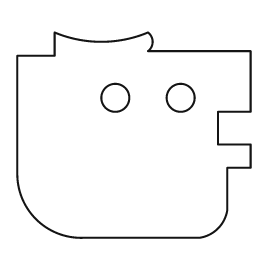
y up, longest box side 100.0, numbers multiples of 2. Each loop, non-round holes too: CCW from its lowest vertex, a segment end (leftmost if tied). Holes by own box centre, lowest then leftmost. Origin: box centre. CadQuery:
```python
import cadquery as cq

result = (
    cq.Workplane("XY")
    .moveTo(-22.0, -44.0)
    .lineTo(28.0, -44.0)
    .threePointArc((36.0, -40.0), (40.0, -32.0))
    .lineTo(40.0, -14.0)
    .lineTo(50.0, -14.0)
    .lineTo(50.0, -4.0)
    .lineTo(36.0, -4.0)
    .lineTo(36.0, 10.0)
    .lineTo(50.0, 10.0)
    .lineTo(50.0, 36.0)
    .lineTo(6.0, 36.0)
    .threePointArc((8.0, 40.0), (6.0, 44.0))
    .threePointArc((-14.0, 40.0), (-34.0, 44.0))
    .lineTo(-34.0, 34.0)
    .lineTo(-50.0, 34.0)
    .lineTo(-50.0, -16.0)
    .threePointArc((-42.0, -36.0), (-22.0, -44.0))
    .close()
    .moveTo(-8.0, 16.0)
    .circle(6.0)
    .moveTo(20.0, 16.0)
    .circle(6.0)
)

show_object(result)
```